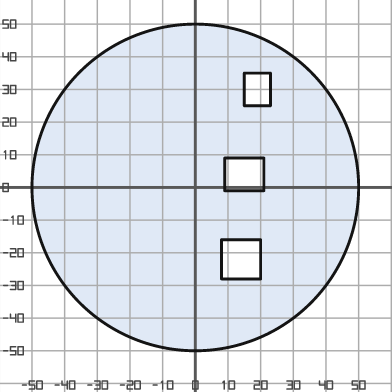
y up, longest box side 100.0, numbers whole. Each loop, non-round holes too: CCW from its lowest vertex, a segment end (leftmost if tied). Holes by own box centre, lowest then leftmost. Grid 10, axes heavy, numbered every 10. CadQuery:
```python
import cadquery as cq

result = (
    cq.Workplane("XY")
    .moveTo(0.0, 0.0)
    .circle(50.0)
    .moveTo(8.0, -28.0)
    .lineTo(20.0, -28.0)
    .lineTo(20.0, -16.0)
    .lineTo(8.0, -16.0)
    .close()
    .moveTo(9.0, -1.0)
    .lineTo(21.0, -1.0)
    .lineTo(21.0, 9.0)
    .lineTo(9.0, 9.0)
    .close()
    .moveTo(15.0, 25.0)
    .lineTo(23.0, 25.0)
    .lineTo(23.0, 35.0)
    .lineTo(15.0, 35.0)
    .close()
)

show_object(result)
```